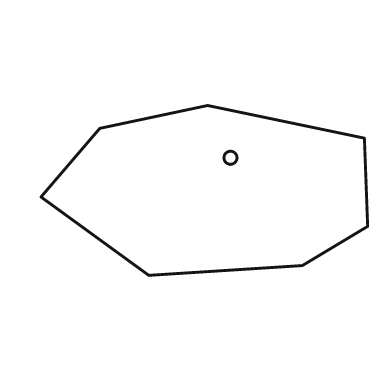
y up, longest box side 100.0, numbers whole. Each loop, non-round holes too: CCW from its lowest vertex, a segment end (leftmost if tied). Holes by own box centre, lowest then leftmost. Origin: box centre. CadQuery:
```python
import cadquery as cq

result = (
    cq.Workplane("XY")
    .moveTo(-17.0, -26.0)
    .lineTo(30.0, -23.0)
    .lineTo(50.0, -11.0)
    .lineTo(49.0, 16.0)
    .lineTo(1.0, 26.0)
    .lineTo(-32.0, 19.0)
    .lineTo(-50.0, -2.0)
    .close()
    .moveTo(8.0, 10.0)
    .circle(2.0)
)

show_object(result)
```